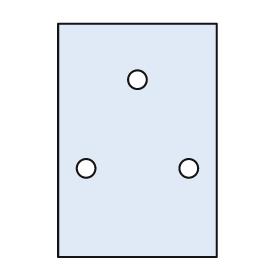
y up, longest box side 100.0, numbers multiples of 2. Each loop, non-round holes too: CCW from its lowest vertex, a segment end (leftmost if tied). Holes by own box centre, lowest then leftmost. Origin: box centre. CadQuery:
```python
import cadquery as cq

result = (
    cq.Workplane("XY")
    .moveTo(-34.0, -50.0)
    .lineTo(34.0, -50.0)
    .lineTo(34.0, 50.0)
    .lineTo(-34.0, 50.0)
    .close()
    .moveTo(-22.0, -12.0)
    .circle(4.0)
    .moveTo(22.0, -12.0)
    .circle(4.0)
    .moveTo(0.0, 26.0)
    .circle(4.0)
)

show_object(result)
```